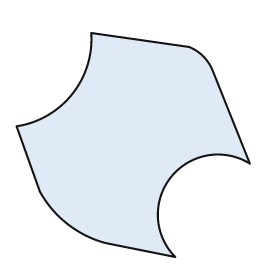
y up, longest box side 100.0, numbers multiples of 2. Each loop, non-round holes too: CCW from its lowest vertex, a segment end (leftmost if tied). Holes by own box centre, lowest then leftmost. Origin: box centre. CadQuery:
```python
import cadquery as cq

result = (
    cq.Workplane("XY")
    .moveTo(18.0, -48.0)
    .threePointArc((16.0, -14.0), (50.0, -8.0))
    .lineTo(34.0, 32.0)
    .threePointArc((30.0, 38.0), (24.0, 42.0))
    .lineTo(-18.0, 48.0)
    .threePointArc((-26.0, 22.0), (-50.0, 8.0))
    .lineTo(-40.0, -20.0)
    .threePointArc((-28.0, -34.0), (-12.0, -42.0))
    .close()
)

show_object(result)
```